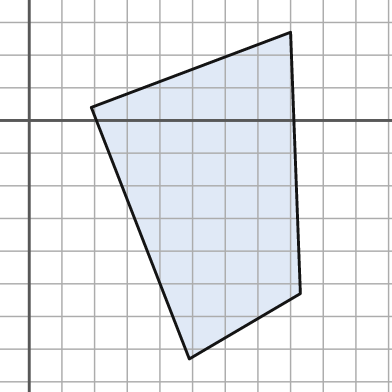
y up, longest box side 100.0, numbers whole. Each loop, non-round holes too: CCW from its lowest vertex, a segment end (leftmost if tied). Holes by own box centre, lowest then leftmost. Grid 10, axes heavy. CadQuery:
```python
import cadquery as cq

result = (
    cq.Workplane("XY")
    .moveTo(49.0, -73.0)
    .lineTo(83.0, -53.0)
    .lineTo(80.0, 27.0)
    .lineTo(19.0, 4.0)
    .close()
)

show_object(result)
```